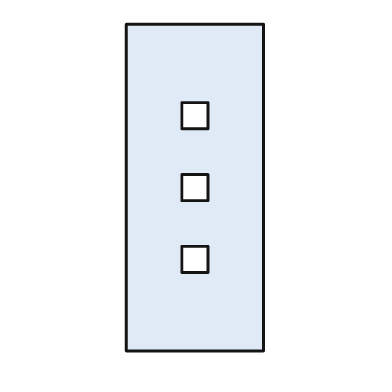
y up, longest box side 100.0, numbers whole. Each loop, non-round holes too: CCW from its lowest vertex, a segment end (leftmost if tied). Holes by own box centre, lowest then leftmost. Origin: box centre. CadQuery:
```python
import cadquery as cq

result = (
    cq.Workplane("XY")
    .moveTo(-21.0, -50.0)
    .lineTo(21.0, -50.0)
    .lineTo(21.0, 50.0)
    .lineTo(-21.0, 50.0)
    .close()
    .moveTo(-4.0, -26.0)
    .lineTo(4.0, -26.0)
    .lineTo(4.0, -18.0)
    .lineTo(-4.0, -18.0)
    .close()
    .moveTo(-4.0, -4.0)
    .lineTo(4.0, -4.0)
    .lineTo(4.0, 4.0)
    .lineTo(-4.0, 4.0)
    .close()
    .moveTo(-4.0, 18.0)
    .lineTo(4.0, 18.0)
    .lineTo(4.0, 26.0)
    .lineTo(-4.0, 26.0)
    .close()
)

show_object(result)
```